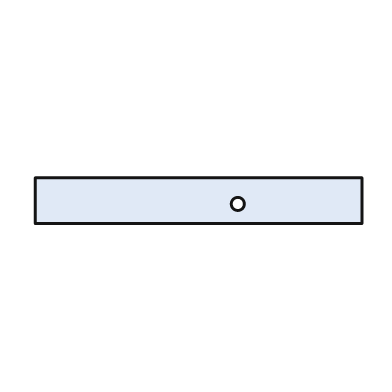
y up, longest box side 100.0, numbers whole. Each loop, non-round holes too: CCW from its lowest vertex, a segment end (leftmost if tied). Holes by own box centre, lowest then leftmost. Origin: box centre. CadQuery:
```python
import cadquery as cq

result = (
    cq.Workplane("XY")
    .moveTo(-50.0, -7.0)
    .lineTo(50.0, -7.0)
    .lineTo(50.0, 7.0)
    .lineTo(-50.0, 7.0)
    .close()
    .moveTo(12.0, -1.0)
    .circle(2.0)
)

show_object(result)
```